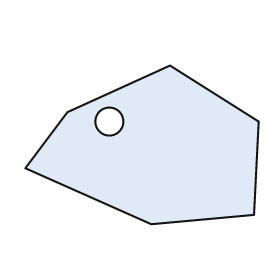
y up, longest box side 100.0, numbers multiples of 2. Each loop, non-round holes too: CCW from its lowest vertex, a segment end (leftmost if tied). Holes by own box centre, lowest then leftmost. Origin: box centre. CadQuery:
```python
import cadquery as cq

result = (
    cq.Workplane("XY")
    .moveTo(4.0, -34.0)
    .lineTo(48.0, -30.0)
    .lineTo(50.0, 10.0)
    .lineTo(12.0, 34.0)
    .lineTo(-32.0, 14.0)
    .lineTo(-50.0, -10.0)
    .close()
    .moveTo(-14.0, 10.0)
    .circle(6.0)
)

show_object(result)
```